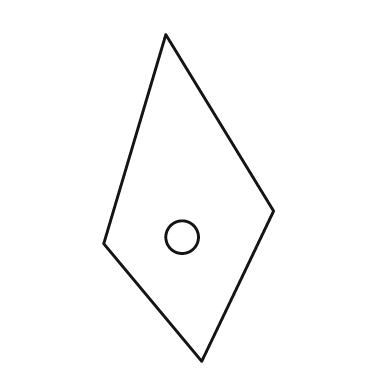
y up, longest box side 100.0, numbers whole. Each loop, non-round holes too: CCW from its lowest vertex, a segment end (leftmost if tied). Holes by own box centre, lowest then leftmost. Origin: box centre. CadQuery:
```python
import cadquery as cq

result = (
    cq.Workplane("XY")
    .moveTo(4.0, -50.0)
    .lineTo(26.0, -4.0)
    .lineTo(-7.0, 50.0)
    .lineTo(-26.0, -14.0)
    .close()
    .moveTo(-2.0, -12.0)
    .circle(5.0)
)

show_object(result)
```